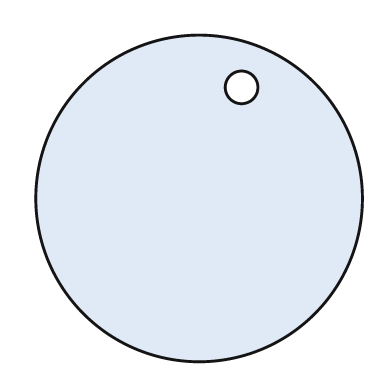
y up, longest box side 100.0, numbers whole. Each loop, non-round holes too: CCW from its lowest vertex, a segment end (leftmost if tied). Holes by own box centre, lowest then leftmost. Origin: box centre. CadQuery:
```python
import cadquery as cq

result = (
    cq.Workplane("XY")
    .moveTo(0.0, 0.0)
    .circle(50.0)
    .moveTo(13.0, 34.0)
    .circle(5.0)
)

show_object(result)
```